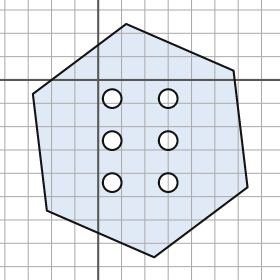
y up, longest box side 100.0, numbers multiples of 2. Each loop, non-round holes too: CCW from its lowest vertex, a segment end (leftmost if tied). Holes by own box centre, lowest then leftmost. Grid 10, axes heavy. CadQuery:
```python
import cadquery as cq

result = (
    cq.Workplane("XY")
    .moveTo(24.0, -76.0)
    .lineTo(64.0, -46.0)
    .lineTo(58.0, 4.0)
    .lineTo(12.0, 24.0)
    .lineTo(-28.0, -6.0)
    .lineTo(-22.0, -56.0)
    .close()
    .moveTo(6.0, -44.0)
    .circle(4.0)
    .moveTo(30.0, -44.0)
    .circle(4.0)
    .moveTo(6.0, -26.0)
    .circle(4.0)
    .moveTo(30.0, -26.0)
    .circle(4.0)
    .moveTo(6.0, -8.0)
    .circle(4.0)
    .moveTo(30.0, -8.0)
    .circle(4.0)
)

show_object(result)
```